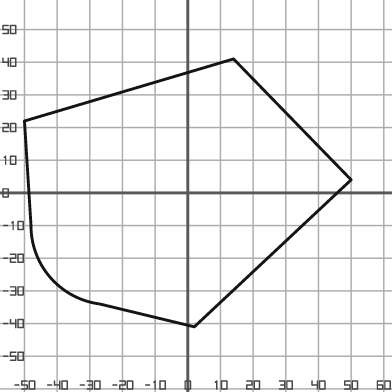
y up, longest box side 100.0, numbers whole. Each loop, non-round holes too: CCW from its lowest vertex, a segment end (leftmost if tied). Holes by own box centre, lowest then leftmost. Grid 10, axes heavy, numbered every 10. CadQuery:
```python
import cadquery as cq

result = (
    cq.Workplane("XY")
    .moveTo(2.0, -41.0)
    .lineTo(50.0, 4.0)
    .lineTo(14.0, 41.0)
    .lineTo(-50.0, 22.0)
    .lineTo(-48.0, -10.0)
    .threePointArc((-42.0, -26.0), (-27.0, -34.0))
    .close()
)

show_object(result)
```